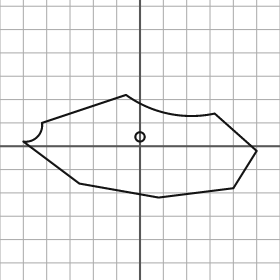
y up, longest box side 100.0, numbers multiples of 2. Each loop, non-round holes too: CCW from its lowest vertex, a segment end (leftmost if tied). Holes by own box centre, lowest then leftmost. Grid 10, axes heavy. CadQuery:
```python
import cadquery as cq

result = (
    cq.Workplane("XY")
    .moveTo(8.0, -22.0)
    .lineTo(40.0, -18.0)
    .lineTo(50.0, -2.0)
    .lineTo(32.0, 14.0)
    .threePointArc((12.0, 14.0), (-6.0, 22.0))
    .lineTo(-42.0, 10.0)
    .threePointArc((-44.0, 4.0), (-50.0, 2.0))
    .lineTo(-26.0, -16.0)
    .close()
    .moveTo(0.0, 4.0)
    .circle(2.0)
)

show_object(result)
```